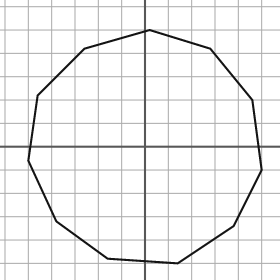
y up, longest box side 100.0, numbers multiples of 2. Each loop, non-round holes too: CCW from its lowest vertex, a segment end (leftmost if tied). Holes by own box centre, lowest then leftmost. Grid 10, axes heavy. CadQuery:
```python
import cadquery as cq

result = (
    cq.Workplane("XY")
    .moveTo(14.0, -50.0)
    .lineTo(38.0, -34.0)
    .lineTo(50.0, -10.0)
    .lineTo(46.0, 20.0)
    .lineTo(28.0, 42.0)
    .lineTo(2.0, 50.0)
    .lineTo(-26.0, 42.0)
    .lineTo(-46.0, 22.0)
    .lineTo(-50.0, -6.0)
    .lineTo(-38.0, -32.0)
    .lineTo(-16.0, -48.0)
    .close()
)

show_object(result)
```